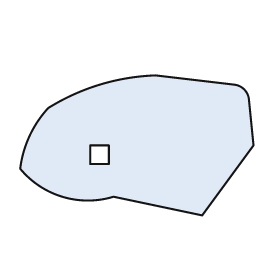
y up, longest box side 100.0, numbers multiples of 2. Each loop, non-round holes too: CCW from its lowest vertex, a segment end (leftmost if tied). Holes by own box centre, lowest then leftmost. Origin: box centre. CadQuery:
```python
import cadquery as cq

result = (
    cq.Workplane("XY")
    .moveTo(28.0, -30.0)
    .lineTo(50.0, 0.0)
    .lineTo(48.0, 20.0)
    .threePointArc((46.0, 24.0), (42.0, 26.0))
    .lineTo(8.0, 30.0)
    .threePointArc((-16.0, 26.0), (-38.0, 16.0))
    .threePointArc((-46.0, 4.0), (-50.0, -10.0))
    .threePointArc((-32.0, -22.0), (-10.0, -22.0))
    .close()
    .moveTo(-20.0, -8.0)
    .lineTo(-12.0, -8.0)
    .lineTo(-12.0, 0.0)
    .lineTo(-20.0, 0.0)
    .close()
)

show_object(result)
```